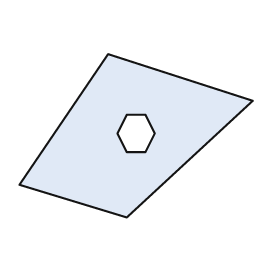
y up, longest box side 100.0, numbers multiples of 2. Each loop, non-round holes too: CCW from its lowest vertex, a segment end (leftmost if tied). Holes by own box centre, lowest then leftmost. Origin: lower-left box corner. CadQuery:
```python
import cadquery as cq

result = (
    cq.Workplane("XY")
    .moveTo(46.0, 0.0)
    .lineTo(100.0, 50.0)
    .lineTo(38.0, 70.0)
    .lineTo(0.0, 14.0)
    .close()
    .moveTo(46.0, 28.0)
    .lineTo(54.0, 28.0)
    .lineTo(58.0, 36.0)
    .lineTo(54.0, 44.0)
    .lineTo(46.0, 44.0)
    .lineTo(42.0, 36.0)
    .close()
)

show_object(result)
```